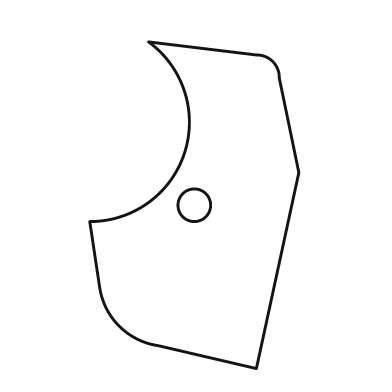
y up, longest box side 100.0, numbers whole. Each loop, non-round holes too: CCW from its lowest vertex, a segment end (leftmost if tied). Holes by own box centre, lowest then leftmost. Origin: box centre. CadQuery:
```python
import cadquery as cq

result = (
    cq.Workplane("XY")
    .moveTo(19.0, -50.0)
    .lineTo(32.0, 10.0)
    .lineTo(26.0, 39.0)
    .threePointArc((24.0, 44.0), (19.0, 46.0))
    .lineTo(-14.0, 50.0)
    .threePointArc((-3.0, 16.0), (-32.0, -5.0))
    .lineTo(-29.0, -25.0)
    .threePointArc((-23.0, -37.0), (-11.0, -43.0))
    .close()
    .moveTo(0.0, 0.0)
    .circle(5.0)
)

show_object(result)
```